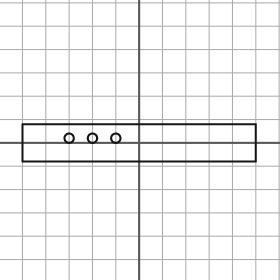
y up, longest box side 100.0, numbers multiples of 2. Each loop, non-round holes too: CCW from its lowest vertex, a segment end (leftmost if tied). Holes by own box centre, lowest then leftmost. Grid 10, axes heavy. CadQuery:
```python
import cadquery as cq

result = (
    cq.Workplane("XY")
    .moveTo(-50.0, -8.0)
    .lineTo(50.0, -8.0)
    .lineTo(50.0, 8.0)
    .lineTo(-50.0, 8.0)
    .close()
    .moveTo(-30.0, 2.0)
    .circle(2.0)
    .moveTo(-20.0, 2.0)
    .circle(2.0)
    .moveTo(-10.0, 2.0)
    .circle(2.0)
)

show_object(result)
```